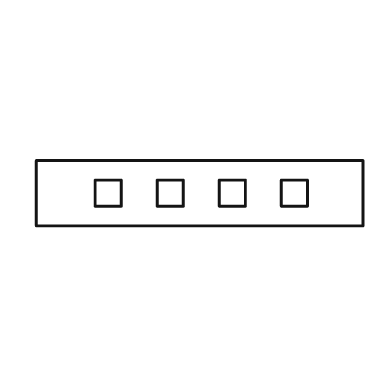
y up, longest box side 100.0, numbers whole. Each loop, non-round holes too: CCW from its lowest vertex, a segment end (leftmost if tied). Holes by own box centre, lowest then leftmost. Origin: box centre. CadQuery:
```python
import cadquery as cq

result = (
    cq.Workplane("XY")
    .moveTo(-50.0, -10.0)
    .lineTo(50.0, -10.0)
    .lineTo(50.0, 10.0)
    .lineTo(-50.0, 10.0)
    .close()
    .moveTo(-32.0, -4.0)
    .lineTo(-24.0, -4.0)
    .lineTo(-24.0, 4.0)
    .lineTo(-32.0, 4.0)
    .close()
    .moveTo(-13.0, -4.0)
    .lineTo(-5.0, -4.0)
    .lineTo(-5.0, 4.0)
    .lineTo(-13.0, 4.0)
    .close()
    .moveTo(6.0, -4.0)
    .lineTo(14.0, -4.0)
    .lineTo(14.0, 4.0)
    .lineTo(6.0, 4.0)
    .close()
    .moveTo(25.0, -4.0)
    .lineTo(33.0, -4.0)
    .lineTo(33.0, 4.0)
    .lineTo(25.0, 4.0)
    .close()
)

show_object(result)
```